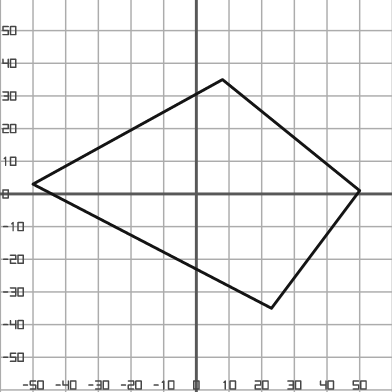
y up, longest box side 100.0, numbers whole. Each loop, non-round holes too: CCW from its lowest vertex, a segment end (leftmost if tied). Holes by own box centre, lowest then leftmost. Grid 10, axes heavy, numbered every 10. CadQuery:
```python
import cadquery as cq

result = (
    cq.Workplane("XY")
    .moveTo(23.0, -35.0)
    .lineTo(50.0, 1.0)
    .lineTo(8.0, 35.0)
    .lineTo(-50.0, 3.0)
    .close()
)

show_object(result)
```